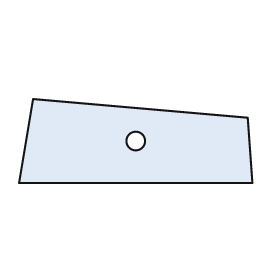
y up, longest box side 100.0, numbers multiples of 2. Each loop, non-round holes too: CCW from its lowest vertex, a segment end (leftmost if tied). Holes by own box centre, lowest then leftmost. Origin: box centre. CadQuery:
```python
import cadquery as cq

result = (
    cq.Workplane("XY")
    .moveTo(-50.0, -18.0)
    .lineTo(50.0, -18.0)
    .lineTo(48.0, 10.0)
    .lineTo(-44.0, 18.0)
    .close()
    .moveTo(0.0, 0.0)
    .circle(4.0)
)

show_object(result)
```